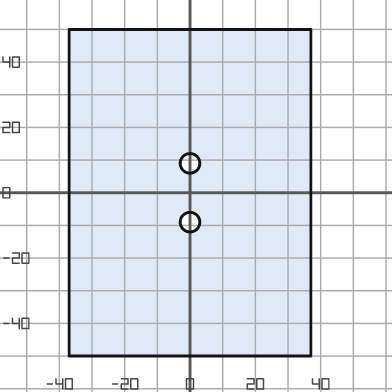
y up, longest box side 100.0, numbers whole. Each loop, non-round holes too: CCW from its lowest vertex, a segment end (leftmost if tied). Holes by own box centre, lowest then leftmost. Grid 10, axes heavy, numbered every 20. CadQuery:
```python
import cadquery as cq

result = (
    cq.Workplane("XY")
    .moveTo(-37.0, -50.0)
    .lineTo(37.0, -50.0)
    .lineTo(37.0, 50.0)
    .lineTo(-37.0, 50.0)
    .close()
    .moveTo(0.0, -9.0)
    .circle(3.0)
    .moveTo(0.0, 9.0)
    .circle(3.0)
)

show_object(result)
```